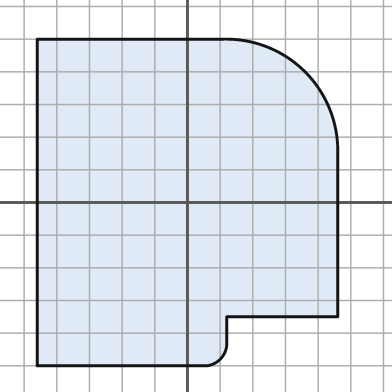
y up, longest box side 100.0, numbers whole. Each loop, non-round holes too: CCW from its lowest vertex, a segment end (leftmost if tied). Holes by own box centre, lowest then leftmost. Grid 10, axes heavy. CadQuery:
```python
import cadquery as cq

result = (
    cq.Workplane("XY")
    .moveTo(-46.0, -50.0)
    .lineTo(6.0, -50.0)
    .threePointArc((10.0, -48.0), (12.0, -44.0))
    .lineTo(12.0, -35.0)
    .lineTo(46.0, -35.0)
    .lineTo(46.0, 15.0)
    .threePointArc((36.0, 40.0), (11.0, 50.0))
    .lineTo(-46.0, 50.0)
    .close()
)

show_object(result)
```